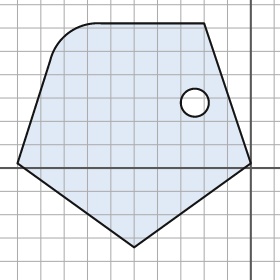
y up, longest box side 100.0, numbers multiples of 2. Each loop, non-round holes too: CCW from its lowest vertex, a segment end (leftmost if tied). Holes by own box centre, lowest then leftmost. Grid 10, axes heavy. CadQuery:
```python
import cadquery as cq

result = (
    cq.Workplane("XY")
    .moveTo(-50.0, -34.0)
    .lineTo(0.0, 2.0)
    .lineTo(-20.0, 62.0)
    .lineTo(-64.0, 62.0)
    .threePointArc((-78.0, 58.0), (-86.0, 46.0))
    .lineTo(-100.0, 2.0)
    .close()
    .moveTo(-24.0, 28.0)
    .circle(6.0)
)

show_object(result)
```